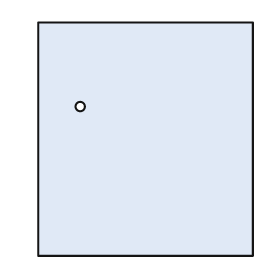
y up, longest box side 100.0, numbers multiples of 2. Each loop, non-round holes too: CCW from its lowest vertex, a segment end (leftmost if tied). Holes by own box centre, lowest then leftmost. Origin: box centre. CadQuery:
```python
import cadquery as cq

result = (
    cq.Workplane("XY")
    .moveTo(-46.0, -50.0)
    .lineTo(46.0, -50.0)
    .lineTo(46.0, 50.0)
    .lineTo(-46.0, 50.0)
    .close()
    .moveTo(-28.0, 14.0)
    .circle(2.0)
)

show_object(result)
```